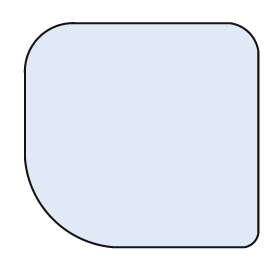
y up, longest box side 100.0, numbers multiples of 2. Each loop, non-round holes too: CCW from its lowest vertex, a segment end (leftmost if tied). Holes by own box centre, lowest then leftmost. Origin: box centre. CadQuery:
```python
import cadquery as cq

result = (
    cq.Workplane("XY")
    .moveTo(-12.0, -48.0)
    .lineTo(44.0, -48.0)
    .threePointArc((48.0, -46.0), (50.0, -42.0))
    .lineTo(50.0, 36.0)
    .threePointArc((46.0, 44.0), (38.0, 48.0))
    .lineTo(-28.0, 48.0)
    .threePointArc((-44.0, 42.0), (-50.0, 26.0))
    .lineTo(-50.0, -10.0)
    .threePointArc((-38.0, -36.0), (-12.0, -48.0))
    .close()
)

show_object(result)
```